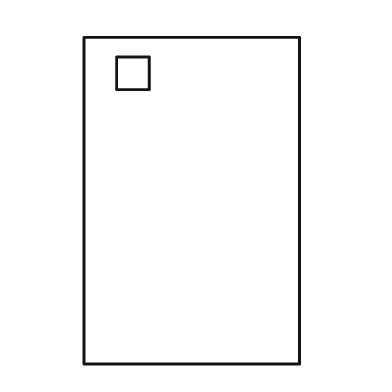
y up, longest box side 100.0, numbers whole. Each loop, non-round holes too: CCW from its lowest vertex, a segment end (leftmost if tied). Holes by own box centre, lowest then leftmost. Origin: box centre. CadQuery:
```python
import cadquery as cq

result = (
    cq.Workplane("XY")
    .moveTo(-33.0, -50.0)
    .lineTo(33.0, -50.0)
    .lineTo(33.0, 50.0)
    .lineTo(-33.0, 50.0)
    .close()
    .moveTo(-23.0, 34.0)
    .lineTo(-13.0, 34.0)
    .lineTo(-13.0, 44.0)
    .lineTo(-23.0, 44.0)
    .close()
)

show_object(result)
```